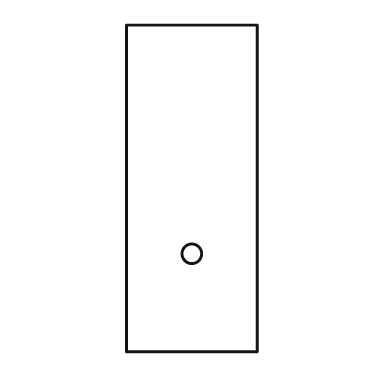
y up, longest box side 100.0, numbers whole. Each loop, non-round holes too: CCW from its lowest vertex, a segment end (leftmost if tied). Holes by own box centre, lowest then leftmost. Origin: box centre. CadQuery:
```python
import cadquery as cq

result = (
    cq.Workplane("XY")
    .moveTo(-20.0, -50.0)
    .lineTo(20.0, -50.0)
    .lineTo(20.0, 50.0)
    .lineTo(-20.0, 50.0)
    .close()
    .moveTo(0.0, -20.0)
    .circle(3.0)
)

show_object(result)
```